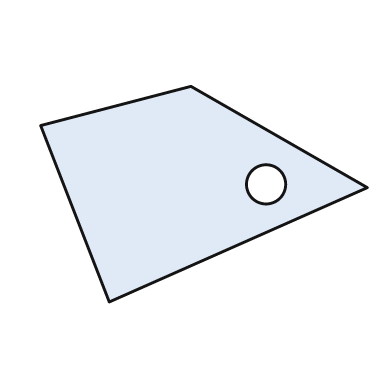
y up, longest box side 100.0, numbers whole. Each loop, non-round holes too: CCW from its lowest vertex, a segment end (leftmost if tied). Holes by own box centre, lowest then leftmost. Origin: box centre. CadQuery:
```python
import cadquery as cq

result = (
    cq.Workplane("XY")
    .moveTo(-29.0, -33.0)
    .lineTo(50.0, 2.0)
    .lineTo(-4.0, 33.0)
    .lineTo(-50.0, 21.0)
    .close()
    .moveTo(19.0, 3.0)
    .circle(6.0)
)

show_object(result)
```